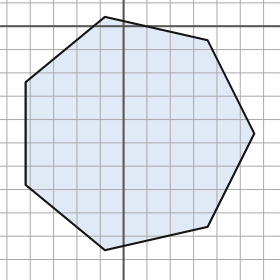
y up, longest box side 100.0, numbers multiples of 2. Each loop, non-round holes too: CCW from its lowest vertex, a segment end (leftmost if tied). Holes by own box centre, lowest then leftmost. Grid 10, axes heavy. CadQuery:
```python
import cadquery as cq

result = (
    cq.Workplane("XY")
    .moveTo(-8.0, -96.0)
    .lineTo(36.0, -86.0)
    .lineTo(56.0, -46.0)
    .lineTo(36.0, -6.0)
    .lineTo(-8.0, 4.0)
    .lineTo(-42.0, -24.0)
    .lineTo(-42.0, -68.0)
    .close()
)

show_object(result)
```